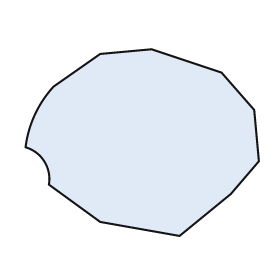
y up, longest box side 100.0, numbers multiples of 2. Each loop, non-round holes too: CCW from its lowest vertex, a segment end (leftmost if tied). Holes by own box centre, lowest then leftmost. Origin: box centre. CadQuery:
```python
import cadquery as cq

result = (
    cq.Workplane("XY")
    .moveTo(16.0, -40.0)
    .lineTo(38.0, -22.0)
    .lineTo(50.0, -8.0)
    .lineTo(48.0, 14.0)
    .lineTo(34.0, 30.0)
    .lineTo(4.0, 40.0)
    .lineTo(-18.0, 38.0)
    .lineTo(-38.0, 24.0)
    .threePointArc((-46.0, 12.0), (-50.0, -2.0))
    .threePointArc((-42.0, -8.0), (-40.0, -18.0))
    .lineTo(-18.0, -34.0)
    .close()
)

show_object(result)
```